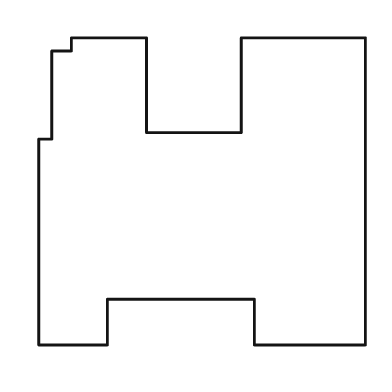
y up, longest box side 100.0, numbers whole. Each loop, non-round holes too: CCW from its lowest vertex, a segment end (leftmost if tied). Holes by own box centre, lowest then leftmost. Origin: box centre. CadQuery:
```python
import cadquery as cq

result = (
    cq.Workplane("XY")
    .moveTo(-50.0, -47.0)
    .lineTo(-29.0, -47.0)
    .lineTo(-29.0, -33.0)
    .lineTo(16.0, -33.0)
    .lineTo(16.0, -47.0)
    .lineTo(50.0, -47.0)
    .lineTo(50.0, 47.0)
    .lineTo(12.0, 47.0)
    .lineTo(12.0, 18.0)
    .lineTo(-17.0, 18.0)
    .lineTo(-17.0, 47.0)
    .lineTo(-40.0, 47.0)
    .lineTo(-40.0, 43.0)
    .lineTo(-46.0, 43.0)
    .lineTo(-46.0, 16.0)
    .lineTo(-50.0, 16.0)
    .close()
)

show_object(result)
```